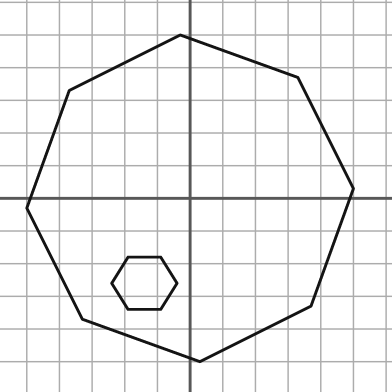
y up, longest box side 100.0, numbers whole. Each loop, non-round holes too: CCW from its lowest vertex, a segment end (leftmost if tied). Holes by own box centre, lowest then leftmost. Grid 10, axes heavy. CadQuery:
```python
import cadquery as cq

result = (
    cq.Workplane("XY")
    .moveTo(3.0, -50.0)
    .lineTo(37.0, -33.0)
    .lineTo(50.0, 3.0)
    .lineTo(33.0, 37.0)
    .lineTo(-3.0, 50.0)
    .lineTo(-37.0, 33.0)
    .lineTo(-50.0, -3.0)
    .lineTo(-33.0, -37.0)
    .close()
    .moveTo(-19.0, -34.0)
    .lineTo(-9.0, -34.0)
    .lineTo(-4.0, -26.0)
    .lineTo(-9.0, -18.0)
    .lineTo(-19.0, -18.0)
    .lineTo(-24.0, -26.0)
    .close()
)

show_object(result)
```